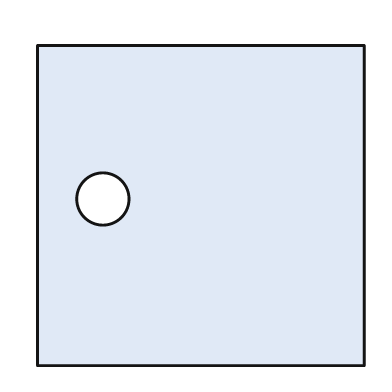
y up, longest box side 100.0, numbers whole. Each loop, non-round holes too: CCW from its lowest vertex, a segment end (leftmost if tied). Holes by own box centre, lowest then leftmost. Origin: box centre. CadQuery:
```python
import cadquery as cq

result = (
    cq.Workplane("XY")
    .moveTo(-50.0, -49.0)
    .lineTo(50.0, -49.0)
    .lineTo(50.0, 49.0)
    .lineTo(-50.0, 49.0)
    .close()
    .moveTo(-30.0, 2.0)
    .circle(8.0)
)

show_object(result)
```